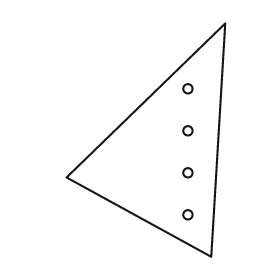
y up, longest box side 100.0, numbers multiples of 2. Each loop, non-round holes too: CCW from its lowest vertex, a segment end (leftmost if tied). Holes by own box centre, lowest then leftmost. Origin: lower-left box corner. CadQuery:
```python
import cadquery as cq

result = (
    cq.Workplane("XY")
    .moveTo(62.0, 0.0)
    .lineTo(68.0, 100.0)
    .lineTo(0.0, 34.0)
    .close()
    .moveTo(52.0, 18.0)
    .circle(2.0)
    .moveTo(52.0, 36.0)
    .circle(2.0)
    .moveTo(52.0, 54.0)
    .circle(2.0)
    .moveTo(52.0, 72.0)
    .circle(2.0)
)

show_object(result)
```